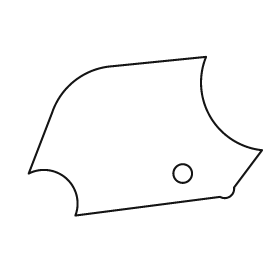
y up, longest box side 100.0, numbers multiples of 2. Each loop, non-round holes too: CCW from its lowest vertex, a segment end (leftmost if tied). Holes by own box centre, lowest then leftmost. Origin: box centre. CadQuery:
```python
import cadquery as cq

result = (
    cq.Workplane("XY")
    .moveTo(-30.0, -34.0)
    .lineTo(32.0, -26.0)
    .threePointArc((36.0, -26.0), (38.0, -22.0))
    .lineTo(50.0, -6.0)
    .threePointArc((28.0, 8.0), (26.0, 34.0))
    .lineTo(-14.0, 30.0)
    .threePointArc((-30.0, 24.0), (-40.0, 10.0))
    .lineTo(-50.0, -16.0)
    .threePointArc((-34.0, -18.0), (-30.0, -34.0))
    .close()
    .moveTo(16.0, -16.0)
    .circle(4.0)
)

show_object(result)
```